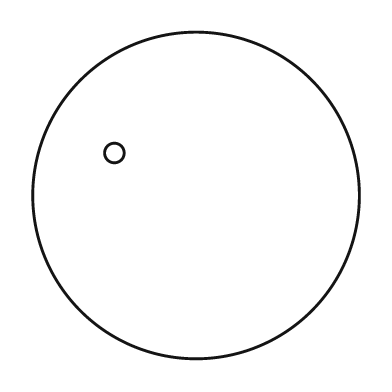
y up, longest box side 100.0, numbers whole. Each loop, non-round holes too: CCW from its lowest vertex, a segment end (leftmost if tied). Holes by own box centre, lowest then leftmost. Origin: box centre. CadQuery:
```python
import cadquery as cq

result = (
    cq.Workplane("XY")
    .moveTo(0.0, 0.0)
    .circle(50.0)
    .moveTo(-25.0, 13.0)
    .circle(3.0)
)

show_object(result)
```